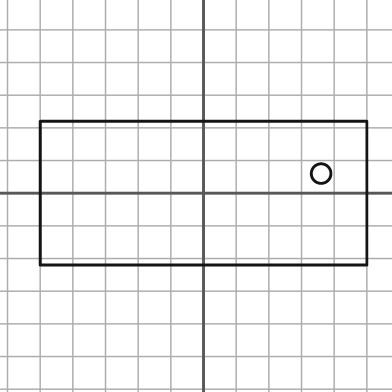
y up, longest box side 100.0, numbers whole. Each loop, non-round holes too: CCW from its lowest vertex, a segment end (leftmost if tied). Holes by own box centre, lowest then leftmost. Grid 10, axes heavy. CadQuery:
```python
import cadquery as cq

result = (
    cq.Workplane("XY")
    .moveTo(-50.0, -22.0)
    .lineTo(50.0, -22.0)
    .lineTo(50.0, 22.0)
    .lineTo(-50.0, 22.0)
    .close()
    .moveTo(36.0, 6.0)
    .circle(3.0)
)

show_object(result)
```